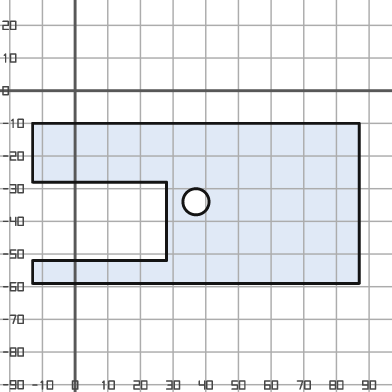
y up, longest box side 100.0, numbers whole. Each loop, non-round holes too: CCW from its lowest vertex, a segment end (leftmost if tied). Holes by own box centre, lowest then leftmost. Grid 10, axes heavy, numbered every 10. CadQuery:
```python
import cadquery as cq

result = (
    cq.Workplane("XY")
    .moveTo(-13.0, -59.0)
    .lineTo(87.0, -59.0)
    .lineTo(87.0, -10.0)
    .lineTo(-13.0, -10.0)
    .lineTo(-13.0, -28.0)
    .lineTo(28.0, -28.0)
    .lineTo(28.0, -52.0)
    .lineTo(-13.0, -52.0)
    .close()
    .moveTo(37.0, -34.0)
    .circle(4.0)
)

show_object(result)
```